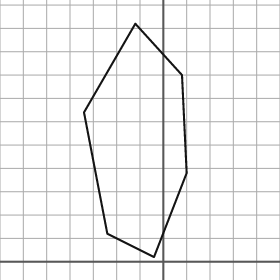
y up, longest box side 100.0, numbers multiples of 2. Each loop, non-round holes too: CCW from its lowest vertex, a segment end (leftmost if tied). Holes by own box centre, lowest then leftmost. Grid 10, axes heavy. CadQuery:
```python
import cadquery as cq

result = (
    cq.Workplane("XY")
    .moveTo(-4.0, 2.0)
    .lineTo(10.0, 38.0)
    .lineTo(8.0, 80.0)
    .lineTo(-12.0, 102.0)
    .lineTo(-34.0, 64.0)
    .lineTo(-24.0, 12.0)
    .close()
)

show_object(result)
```